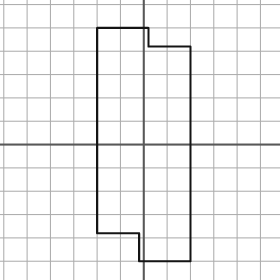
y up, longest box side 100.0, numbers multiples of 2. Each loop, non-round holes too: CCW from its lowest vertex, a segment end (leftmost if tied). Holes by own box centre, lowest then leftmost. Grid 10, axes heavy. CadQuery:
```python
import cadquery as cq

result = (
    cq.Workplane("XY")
    .moveTo(-2.0, -50.0)
    .lineTo(20.0, -50.0)
    .lineTo(20.0, 42.0)
    .lineTo(2.0, 42.0)
    .lineTo(2.0, 50.0)
    .lineTo(-20.0, 50.0)
    .lineTo(-20.0, -38.0)
    .lineTo(-2.0, -38.0)
    .close()
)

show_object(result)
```